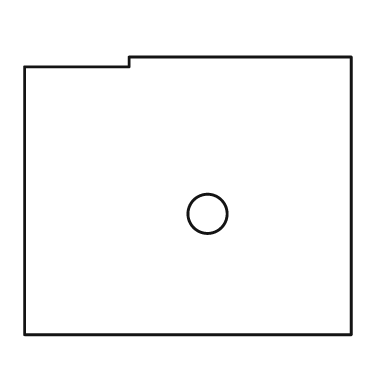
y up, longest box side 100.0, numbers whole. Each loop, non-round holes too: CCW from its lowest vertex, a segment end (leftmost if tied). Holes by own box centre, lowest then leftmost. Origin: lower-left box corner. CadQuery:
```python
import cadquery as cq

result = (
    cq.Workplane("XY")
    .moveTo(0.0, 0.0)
    .lineTo(100.0, 0.0)
    .lineTo(100.0, 85.0)
    .lineTo(32.0, 85.0)
    .lineTo(32.0, 82.0)
    .lineTo(0.0, 82.0)
    .close()
    .moveTo(56.0, 37.0)
    .circle(6.0)
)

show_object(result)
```